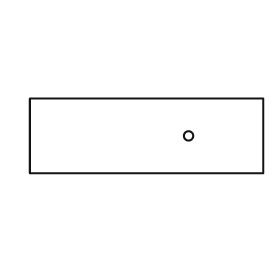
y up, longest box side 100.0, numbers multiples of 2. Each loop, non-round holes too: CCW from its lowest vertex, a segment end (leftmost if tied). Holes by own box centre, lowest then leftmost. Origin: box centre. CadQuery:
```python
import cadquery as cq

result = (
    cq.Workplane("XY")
    .moveTo(-50.0, -16.0)
    .lineTo(50.0, -16.0)
    .lineTo(50.0, 16.0)
    .lineTo(-50.0, 16.0)
    .close()
    .moveTo(18.0, 0.0)
    .circle(2.0)
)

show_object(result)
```